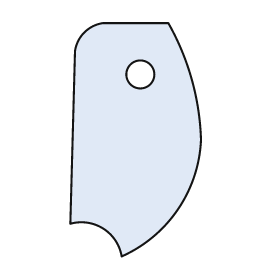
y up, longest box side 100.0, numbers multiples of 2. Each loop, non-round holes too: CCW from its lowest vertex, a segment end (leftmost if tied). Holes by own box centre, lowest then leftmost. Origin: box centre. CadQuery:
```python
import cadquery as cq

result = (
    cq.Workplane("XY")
    .moveTo(-6.0, -50.0)
    .threePointArc((18.0, -30.0), (28.0, 0.0))
    .threePointArc((24.0, 26.0), (14.0, 50.0))
    .lineTo(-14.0, 50.0)
    .threePointArc((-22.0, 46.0), (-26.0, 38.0))
    .lineTo(-28.0, -36.0)
    .threePointArc((-14.0, -38.0), (-6.0, -50.0))
    .close()
    .moveTo(2.0, 28.0)
    .circle(6.0)
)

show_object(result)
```